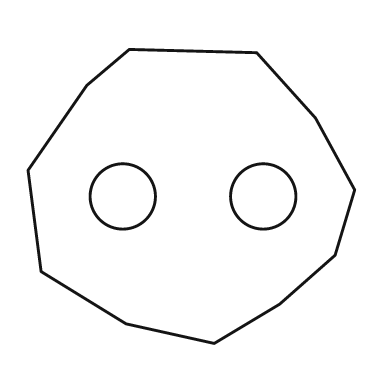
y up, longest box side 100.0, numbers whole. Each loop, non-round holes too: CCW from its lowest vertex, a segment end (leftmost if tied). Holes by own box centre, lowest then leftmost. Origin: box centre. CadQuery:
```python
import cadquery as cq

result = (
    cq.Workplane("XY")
    .moveTo(7.0, -45.0)
    .lineTo(27.0, -33.0)
    .lineTo(44.0, -18.0)
    .lineTo(50.0, 2.0)
    .lineTo(38.0, 24.0)
    .lineTo(20.0, 44.0)
    .lineTo(-19.0, 45.0)
    .lineTo(-32.0, 34.0)
    .lineTo(-50.0, 8.0)
    .lineTo(-46.0, -23.0)
    .lineTo(-20.0, -39.0)
    .close()
    .moveTo(-21.0, 0.0)
    .circle(10.0)
    .moveTo(22.0, 0.0)
    .circle(10.0)
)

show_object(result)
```